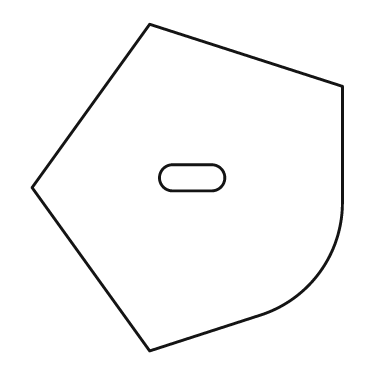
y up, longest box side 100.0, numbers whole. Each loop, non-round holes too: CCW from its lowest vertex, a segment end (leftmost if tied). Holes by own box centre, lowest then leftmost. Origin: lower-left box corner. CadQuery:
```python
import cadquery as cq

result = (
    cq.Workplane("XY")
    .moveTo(36.0, 0.0)
    .lineTo(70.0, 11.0)
    .threePointArc((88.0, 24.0), (95.0, 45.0))
    .lineTo(95.0, 81.0)
    .lineTo(36.0, 100.0)
    .lineTo(0.0, 50.0)
    .close()
    .moveTo(43.0, 49.0)
    .lineTo(55.0, 49.0)
    .threePointArc((59.0, 53.0), (55.0, 57.0))
    .lineTo(43.0, 57.0)
    .threePointArc((39.0, 53.0), (43.0, 49.0))
    .close()
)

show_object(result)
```